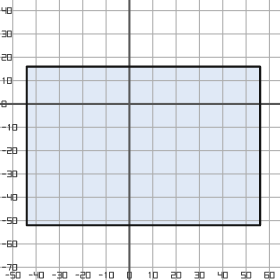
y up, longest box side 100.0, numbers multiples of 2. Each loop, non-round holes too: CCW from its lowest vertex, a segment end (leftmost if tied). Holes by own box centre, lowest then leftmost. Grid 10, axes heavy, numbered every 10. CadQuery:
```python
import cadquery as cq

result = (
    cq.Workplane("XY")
    .moveTo(-44.0, -52.0)
    .lineTo(56.0, -52.0)
    .lineTo(56.0, 16.0)
    .lineTo(-44.0, 16.0)
    .close()
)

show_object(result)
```